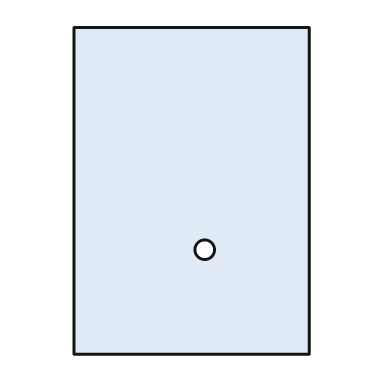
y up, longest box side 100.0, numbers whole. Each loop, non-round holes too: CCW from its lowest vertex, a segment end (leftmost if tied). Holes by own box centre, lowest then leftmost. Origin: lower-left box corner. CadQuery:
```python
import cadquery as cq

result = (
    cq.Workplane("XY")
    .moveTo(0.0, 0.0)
    .lineTo(72.0, 0.0)
    .lineTo(72.0, 100.0)
    .lineTo(0.0, 100.0)
    .close()
    .moveTo(40.0, 32.0)
    .circle(3.0)
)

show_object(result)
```